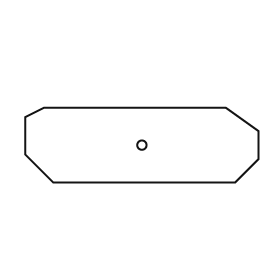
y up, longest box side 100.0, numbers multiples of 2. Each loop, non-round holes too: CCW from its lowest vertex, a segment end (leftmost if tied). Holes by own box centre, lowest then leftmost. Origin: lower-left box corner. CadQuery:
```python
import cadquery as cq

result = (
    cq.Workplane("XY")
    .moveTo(12.0, 0.0)
    .lineTo(90.0, 0.0)
    .lineTo(100.0, 10.0)
    .lineTo(100.0, 22.0)
    .lineTo(86.0, 32.0)
    .lineTo(8.0, 32.0)
    .lineTo(0.0, 28.0)
    .lineTo(0.0, 12.0)
    .close()
    .moveTo(50.0, 16.0)
    .circle(2.0)
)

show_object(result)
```